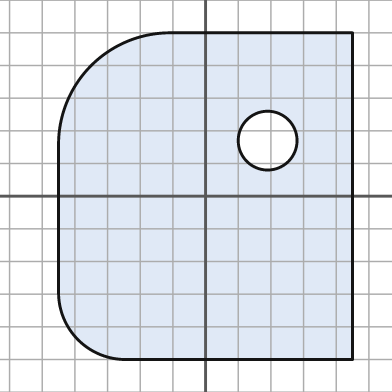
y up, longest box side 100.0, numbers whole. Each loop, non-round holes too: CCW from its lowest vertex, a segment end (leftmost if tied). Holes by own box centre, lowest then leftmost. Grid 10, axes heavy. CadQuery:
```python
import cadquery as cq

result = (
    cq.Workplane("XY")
    .moveTo(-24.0, -50.0)
    .lineTo(45.0, -50.0)
    .lineTo(45.0, 50.0)
    .lineTo(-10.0, 50.0)
    .threePointArc((-35.0, 40.0), (-45.0, 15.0))
    .lineTo(-45.0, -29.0)
    .threePointArc((-39.0, -44.0), (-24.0, -50.0))
    .close()
    .moveTo(19.0, 17.0)
    .circle(9.0)
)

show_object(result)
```